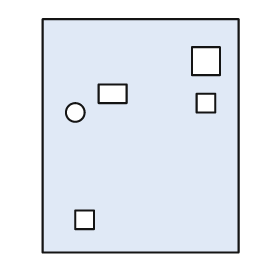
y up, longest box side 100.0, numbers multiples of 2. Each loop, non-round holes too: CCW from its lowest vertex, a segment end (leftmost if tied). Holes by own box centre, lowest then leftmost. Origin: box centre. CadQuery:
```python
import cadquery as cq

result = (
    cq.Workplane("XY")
    .moveTo(-42.0, -50.0)
    .lineTo(42.0, -50.0)
    .lineTo(42.0, 50.0)
    .lineTo(-42.0, 50.0)
    .close()
    .moveTo(-28.0, -40.0)
    .lineTo(-20.0, -40.0)
    .lineTo(-20.0, -32.0)
    .lineTo(-28.0, -32.0)
    .close()
    .moveTo(-28.0, 10.0)
    .circle(4.0)
    .moveTo(24.0, 10.0)
    .lineTo(32.0, 10.0)
    .lineTo(32.0, 18.0)
    .lineTo(24.0, 18.0)
    .close()
    .moveTo(-18.0, 14.0)
    .lineTo(-6.0, 14.0)
    .lineTo(-6.0, 22.0)
    .lineTo(-18.0, 22.0)
    .close()
    .moveTo(22.0, 26.0)
    .lineTo(34.0, 26.0)
    .lineTo(34.0, 38.0)
    .lineTo(22.0, 38.0)
    .close()
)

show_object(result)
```